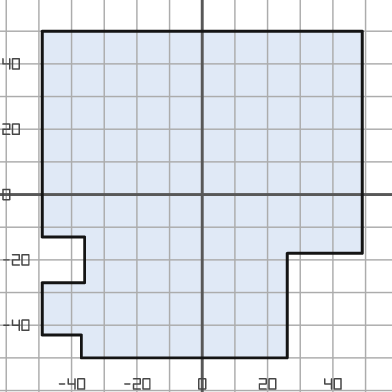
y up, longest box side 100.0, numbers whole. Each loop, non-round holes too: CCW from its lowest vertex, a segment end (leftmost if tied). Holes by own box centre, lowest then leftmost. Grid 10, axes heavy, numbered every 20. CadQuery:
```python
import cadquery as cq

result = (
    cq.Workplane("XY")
    .moveTo(-37.0, -50.0)
    .lineTo(26.0, -50.0)
    .lineTo(26.0, -18.0)
    .lineTo(49.0, -18.0)
    .lineTo(49.0, 50.0)
    .lineTo(-49.0, 50.0)
    .lineTo(-49.0, -13.0)
    .lineTo(-36.0, -13.0)
    .lineTo(-36.0, -27.0)
    .lineTo(-49.0, -27.0)
    .lineTo(-49.0, -43.0)
    .lineTo(-37.0, -43.0)
    .close()
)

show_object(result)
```